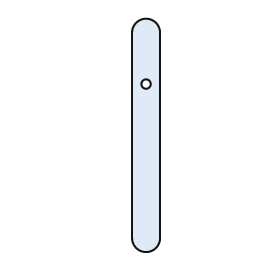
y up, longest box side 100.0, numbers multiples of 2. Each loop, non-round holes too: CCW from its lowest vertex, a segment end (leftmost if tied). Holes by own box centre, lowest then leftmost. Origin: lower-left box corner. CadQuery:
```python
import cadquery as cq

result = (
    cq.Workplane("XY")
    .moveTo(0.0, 6.0)
    .threePointArc((6.0, 0.0), (12.0, 6.0))
    .lineTo(12.0, 94.0)
    .threePointArc((6.0, 100.0), (0.0, 94.0))
    .close()
    .moveTo(6.0, 72.0)
    .circle(2.0)
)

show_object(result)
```